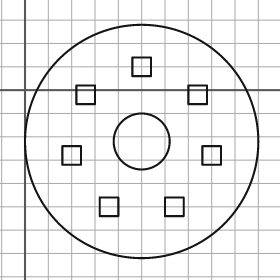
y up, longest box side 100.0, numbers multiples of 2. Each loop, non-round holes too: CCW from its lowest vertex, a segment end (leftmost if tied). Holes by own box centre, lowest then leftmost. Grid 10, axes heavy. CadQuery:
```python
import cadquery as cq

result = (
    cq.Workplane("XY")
    .moveTo(50.0, -22.0)
    .circle(50.0)
    .moveTo(32.0, -54.0)
    .lineTo(40.0, -54.0)
    .lineTo(40.0, -46.0)
    .lineTo(32.0, -46.0)
    .close()
    .moveTo(60.0, -54.0)
    .lineTo(68.0, -54.0)
    .lineTo(68.0, -46.0)
    .lineTo(60.0, -46.0)
    .close()
    .moveTo(16.0, -32.0)
    .lineTo(24.0, -32.0)
    .lineTo(24.0, -24.0)
    .lineTo(16.0, -24.0)
    .close()
    .moveTo(76.0, -32.0)
    .lineTo(84.0, -32.0)
    .lineTo(84.0, -24.0)
    .lineTo(76.0, -24.0)
    .close()
    .moveTo(50.0, -22.0)
    .circle(12.0)
    .moveTo(22.0, -6.0)
    .lineTo(30.0, -6.0)
    .lineTo(30.0, 2.0)
    .lineTo(22.0, 2.0)
    .close()
    .moveTo(70.0, -6.0)
    .lineTo(78.0, -6.0)
    .lineTo(78.0, 2.0)
    .lineTo(70.0, 2.0)
    .close()
    .moveTo(46.0, 6.0)
    .lineTo(54.0, 6.0)
    .lineTo(54.0, 14.0)
    .lineTo(46.0, 14.0)
    .close()
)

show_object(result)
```